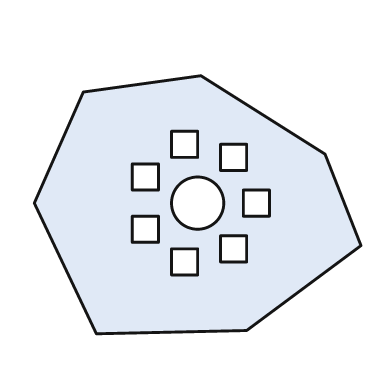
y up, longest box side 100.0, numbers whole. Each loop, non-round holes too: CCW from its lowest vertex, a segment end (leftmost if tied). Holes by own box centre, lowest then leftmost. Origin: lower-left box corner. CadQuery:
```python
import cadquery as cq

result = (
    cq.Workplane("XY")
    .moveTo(19.0, 0.0)
    .lineTo(65.0, 1.0)
    .lineTo(100.0, 27.0)
    .lineTo(89.0, 55.0)
    .lineTo(51.0, 79.0)
    .lineTo(15.0, 74.0)
    .lineTo(0.0, 40.0)
    .close()
    .moveTo(42.0, 18.0)
    .lineTo(50.0, 18.0)
    .lineTo(50.0, 26.0)
    .lineTo(42.0, 26.0)
    .close()
    .moveTo(57.0, 22.0)
    .lineTo(65.0, 22.0)
    .lineTo(65.0, 30.0)
    .lineTo(57.0, 30.0)
    .close()
    .moveTo(30.0, 28.0)
    .lineTo(38.0, 28.0)
    .lineTo(38.0, 36.0)
    .lineTo(30.0, 36.0)
    .close()
    .moveTo(50.0, 40.0)
    .circle(8.0)
    .moveTo(64.0, 36.0)
    .lineTo(72.0, 36.0)
    .lineTo(72.0, 44.0)
    .lineTo(64.0, 44.0)
    .close()
    .moveTo(30.0, 44.0)
    .lineTo(38.0, 44.0)
    .lineTo(38.0, 52.0)
    .lineTo(30.0, 52.0)
    .close()
    .moveTo(57.0, 50.0)
    .lineTo(65.0, 50.0)
    .lineTo(65.0, 58.0)
    .lineTo(57.0, 58.0)
    .close()
    .moveTo(42.0, 54.0)
    .lineTo(50.0, 54.0)
    .lineTo(50.0, 62.0)
    .lineTo(42.0, 62.0)
    .close()
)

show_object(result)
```